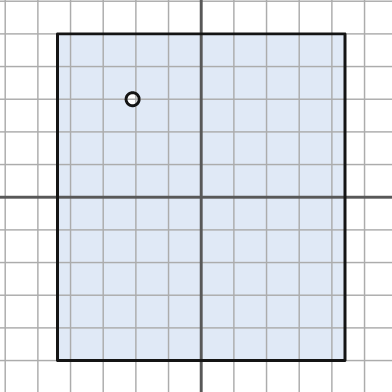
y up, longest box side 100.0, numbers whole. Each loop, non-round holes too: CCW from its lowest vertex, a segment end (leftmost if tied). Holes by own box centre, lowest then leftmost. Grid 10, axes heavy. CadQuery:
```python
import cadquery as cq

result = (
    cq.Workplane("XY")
    .moveTo(-44.0, -50.0)
    .lineTo(44.0, -50.0)
    .lineTo(44.0, 50.0)
    .lineTo(-44.0, 50.0)
    .close()
    .moveTo(-21.0, 30.0)
    .circle(2.0)
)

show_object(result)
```